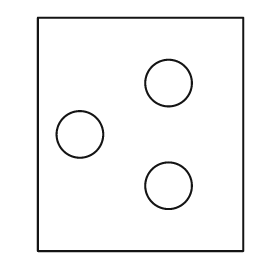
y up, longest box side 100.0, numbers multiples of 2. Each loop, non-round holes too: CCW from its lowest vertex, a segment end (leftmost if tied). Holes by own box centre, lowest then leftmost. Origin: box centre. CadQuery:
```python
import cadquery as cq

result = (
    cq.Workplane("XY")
    .moveTo(-44.0, -50.0)
    .lineTo(44.0, -50.0)
    .lineTo(44.0, 50.0)
    .lineTo(-44.0, 50.0)
    .close()
    .moveTo(12.0, -22.0)
    .circle(10.0)
    .moveTo(-26.0, 0.0)
    .circle(10.0)
    .moveTo(12.0, 22.0)
    .circle(10.0)
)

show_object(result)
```